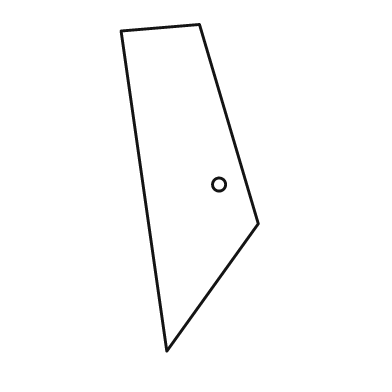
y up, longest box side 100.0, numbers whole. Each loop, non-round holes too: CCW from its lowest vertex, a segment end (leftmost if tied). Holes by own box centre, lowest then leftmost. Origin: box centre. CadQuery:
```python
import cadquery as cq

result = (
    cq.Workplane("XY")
    .moveTo(-7.0, -50.0)
    .lineTo(21.0, -11.0)
    .lineTo(3.0, 50.0)
    .lineTo(-21.0, 48.0)
    .close()
    .moveTo(9.0, 1.0)
    .circle(2.0)
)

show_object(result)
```